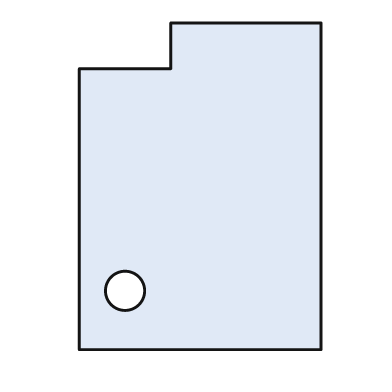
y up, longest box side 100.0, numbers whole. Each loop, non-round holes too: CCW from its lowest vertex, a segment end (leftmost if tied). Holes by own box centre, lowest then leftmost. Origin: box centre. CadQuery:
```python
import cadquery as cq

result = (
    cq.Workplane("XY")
    .moveTo(-37.0, -50.0)
    .lineTo(37.0, -50.0)
    .lineTo(37.0, 50.0)
    .lineTo(-9.0, 50.0)
    .lineTo(-9.0, 36.0)
    .lineTo(-37.0, 36.0)
    .close()
    .moveTo(-23.0, -32.0)
    .circle(6.0)
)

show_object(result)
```